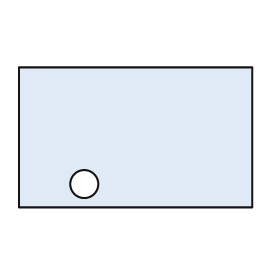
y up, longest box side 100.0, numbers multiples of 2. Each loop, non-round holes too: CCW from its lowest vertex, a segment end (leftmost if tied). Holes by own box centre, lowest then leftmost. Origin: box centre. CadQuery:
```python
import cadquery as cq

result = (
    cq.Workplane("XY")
    .moveTo(-50.0, -30.0)
    .lineTo(50.0, -30.0)
    .lineTo(50.0, 30.0)
    .lineTo(-50.0, 30.0)
    .close()
    .moveTo(-22.0, -20.0)
    .circle(6.0)
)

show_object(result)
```